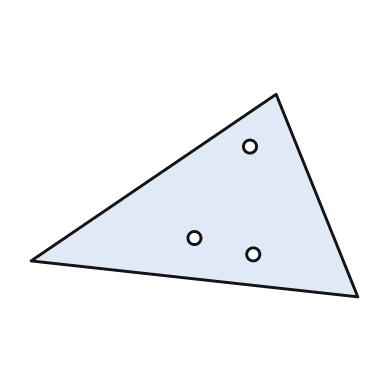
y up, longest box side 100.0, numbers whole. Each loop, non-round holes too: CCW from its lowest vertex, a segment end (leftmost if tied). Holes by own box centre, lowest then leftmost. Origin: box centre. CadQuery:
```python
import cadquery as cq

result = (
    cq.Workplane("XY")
    .moveTo(50.0, -31.0)
    .lineTo(25.0, 31.0)
    .lineTo(-50.0, -20.0)
    .close()
    .moveTo(18.0, -18.0)
    .circle(2.0)
    .moveTo(0.0, -13.0)
    .circle(2.0)
    .moveTo(17.0, 15.0)
    .circle(2.0)
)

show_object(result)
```